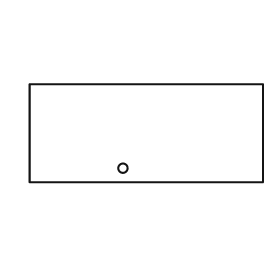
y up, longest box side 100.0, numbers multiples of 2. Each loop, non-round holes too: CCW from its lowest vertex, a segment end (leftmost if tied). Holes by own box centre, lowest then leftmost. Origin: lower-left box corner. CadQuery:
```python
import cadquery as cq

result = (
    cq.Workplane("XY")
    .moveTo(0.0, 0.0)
    .lineTo(100.0, 0.0)
    .lineTo(100.0, 42.0)
    .lineTo(0.0, 42.0)
    .close()
    .moveTo(40.0, 6.0)
    .circle(2.0)
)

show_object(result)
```